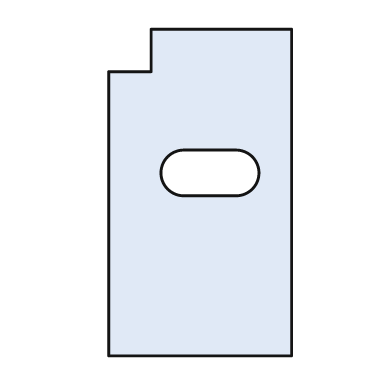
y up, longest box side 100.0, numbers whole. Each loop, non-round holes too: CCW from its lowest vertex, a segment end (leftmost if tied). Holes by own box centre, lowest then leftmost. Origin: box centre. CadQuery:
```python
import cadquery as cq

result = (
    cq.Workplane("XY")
    .moveTo(-28.0, -50.0)
    .lineTo(28.0, -50.0)
    .lineTo(28.0, 50.0)
    .lineTo(-15.0, 50.0)
    .lineTo(-15.0, 37.0)
    .lineTo(-28.0, 37.0)
    .close()
    .moveTo(-5.0, -1.0)
    .lineTo(11.0, -1.0)
    .threePointArc((18.0, 6.0), (11.0, 13.0))
    .lineTo(-5.0, 13.0)
    .threePointArc((-12.0, 6.0), (-5.0, -1.0))
    .close()
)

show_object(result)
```